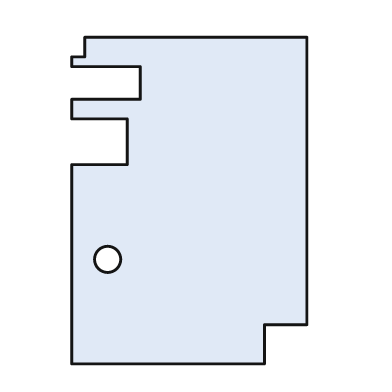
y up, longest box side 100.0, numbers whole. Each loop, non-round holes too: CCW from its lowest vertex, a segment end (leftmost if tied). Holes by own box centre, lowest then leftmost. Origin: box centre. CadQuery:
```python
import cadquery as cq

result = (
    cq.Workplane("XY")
    .moveTo(-36.0, -50.0)
    .lineTo(23.0, -50.0)
    .lineTo(23.0, -38.0)
    .lineTo(36.0, -38.0)
    .lineTo(36.0, 50.0)
    .lineTo(-32.0, 50.0)
    .lineTo(-32.0, 44.0)
    .lineTo(-36.0, 44.0)
    .lineTo(-36.0, 41.0)
    .lineTo(-15.0, 41.0)
    .lineTo(-15.0, 31.0)
    .lineTo(-36.0, 31.0)
    .lineTo(-36.0, 25.0)
    .lineTo(-19.0, 25.0)
    .lineTo(-19.0, 11.0)
    .lineTo(-36.0, 11.0)
    .close()
    .moveTo(-25.0, -18.0)
    .circle(4.0)
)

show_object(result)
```